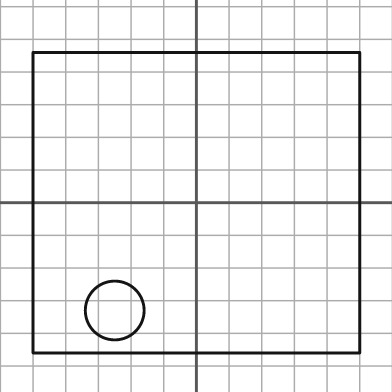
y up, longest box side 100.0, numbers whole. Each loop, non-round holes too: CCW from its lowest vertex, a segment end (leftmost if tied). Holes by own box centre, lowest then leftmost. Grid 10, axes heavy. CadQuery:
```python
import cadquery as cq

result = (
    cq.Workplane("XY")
    .moveTo(-50.0, -46.0)
    .lineTo(50.0, -46.0)
    .lineTo(50.0, 46.0)
    .lineTo(-50.0, 46.0)
    .close()
    .moveTo(-25.0, -33.0)
    .circle(9.0)
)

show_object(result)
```